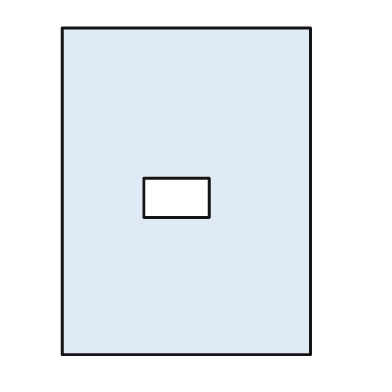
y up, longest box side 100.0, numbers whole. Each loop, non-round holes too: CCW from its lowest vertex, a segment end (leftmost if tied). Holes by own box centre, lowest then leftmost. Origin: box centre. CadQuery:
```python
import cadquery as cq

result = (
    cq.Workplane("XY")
    .moveTo(-38.0, -50.0)
    .lineTo(38.0, -50.0)
    .lineTo(38.0, 50.0)
    .lineTo(-38.0, 50.0)
    .close()
    .moveTo(-13.0, -8.0)
    .lineTo(7.0, -8.0)
    .lineTo(7.0, 4.0)
    .lineTo(-13.0, 4.0)
    .close()
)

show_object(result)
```